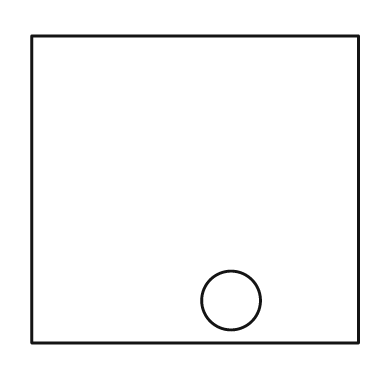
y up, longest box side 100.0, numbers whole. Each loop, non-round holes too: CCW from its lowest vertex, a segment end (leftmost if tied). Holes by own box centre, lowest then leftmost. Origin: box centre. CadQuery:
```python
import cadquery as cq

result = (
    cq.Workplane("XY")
    .moveTo(-50.0, -47.0)
    .lineTo(50.0, -47.0)
    .lineTo(50.0, 47.0)
    .lineTo(-50.0, 47.0)
    .close()
    .moveTo(11.0, -34.0)
    .circle(9.0)
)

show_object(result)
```